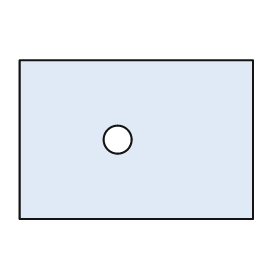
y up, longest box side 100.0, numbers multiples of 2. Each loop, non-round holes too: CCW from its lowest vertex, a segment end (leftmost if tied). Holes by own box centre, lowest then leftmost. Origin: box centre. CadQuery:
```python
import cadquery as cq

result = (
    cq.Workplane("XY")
    .moveTo(-50.0, -34.0)
    .lineTo(50.0, -34.0)
    .lineTo(50.0, 34.0)
    .lineTo(-50.0, 34.0)
    .close()
    .moveTo(-8.0, 0.0)
    .circle(6.0)
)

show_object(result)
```